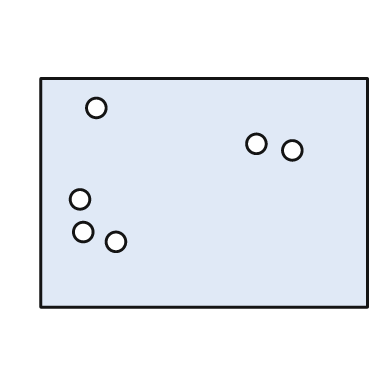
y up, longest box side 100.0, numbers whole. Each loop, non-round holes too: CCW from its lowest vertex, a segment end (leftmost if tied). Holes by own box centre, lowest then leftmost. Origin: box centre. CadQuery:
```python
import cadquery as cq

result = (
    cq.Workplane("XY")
    .moveTo(-50.0, -35.0)
    .lineTo(50.0, -35.0)
    .lineTo(50.0, 35.0)
    .lineTo(-50.0, 35.0)
    .close()
    .moveTo(-27.0, -15.0)
    .circle(3.0)
    .moveTo(-37.0, -12.0)
    .circle(3.0)
    .moveTo(-38.0, -2.0)
    .circle(3.0)
    .moveTo(27.0, 13.0)
    .circle(3.0)
    .moveTo(16.0, 15.0)
    .circle(3.0)
    .moveTo(-33.0, 26.0)
    .circle(3.0)
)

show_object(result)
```